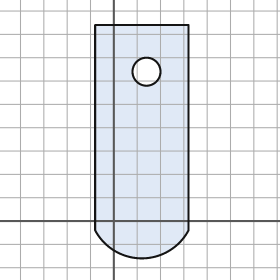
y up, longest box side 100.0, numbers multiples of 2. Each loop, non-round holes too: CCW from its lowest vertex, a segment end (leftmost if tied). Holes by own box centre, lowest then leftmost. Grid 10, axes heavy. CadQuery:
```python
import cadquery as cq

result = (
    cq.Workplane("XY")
    .moveTo(-8.0, -4.0)
    .threePointArc((12.0, -16.0), (32.0, -4.0))
    .lineTo(32.0, 84.0)
    .lineTo(-8.0, 84.0)
    .close()
    .moveTo(14.0, 64.0)
    .circle(6.0)
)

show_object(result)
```